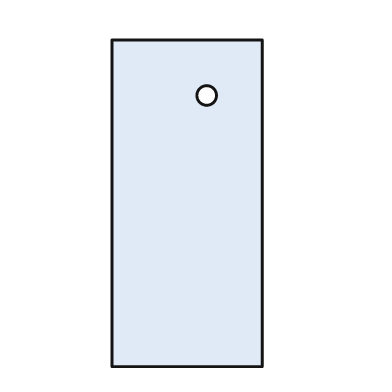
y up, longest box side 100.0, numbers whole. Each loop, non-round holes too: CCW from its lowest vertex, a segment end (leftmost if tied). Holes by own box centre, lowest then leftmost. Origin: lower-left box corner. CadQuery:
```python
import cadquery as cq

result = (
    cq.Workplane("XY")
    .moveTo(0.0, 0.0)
    .lineTo(46.0, 0.0)
    .lineTo(46.0, 100.0)
    .lineTo(0.0, 100.0)
    .close()
    .moveTo(29.0, 83.0)
    .circle(3.0)
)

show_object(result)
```